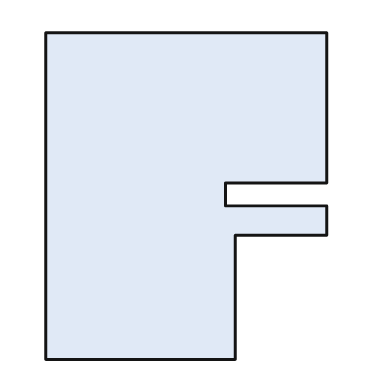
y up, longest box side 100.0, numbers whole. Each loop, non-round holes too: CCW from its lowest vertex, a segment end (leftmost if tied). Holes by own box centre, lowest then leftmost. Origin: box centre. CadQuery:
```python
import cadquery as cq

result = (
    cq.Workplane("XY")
    .moveTo(-43.0, -50.0)
    .lineTo(15.0, -50.0)
    .lineTo(15.0, -12.0)
    .lineTo(43.0, -12.0)
    .lineTo(43.0, -3.0)
    .lineTo(12.0, -3.0)
    .lineTo(12.0, 4.0)
    .lineTo(43.0, 4.0)
    .lineTo(43.0, 50.0)
    .lineTo(-43.0, 50.0)
    .close()
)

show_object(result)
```